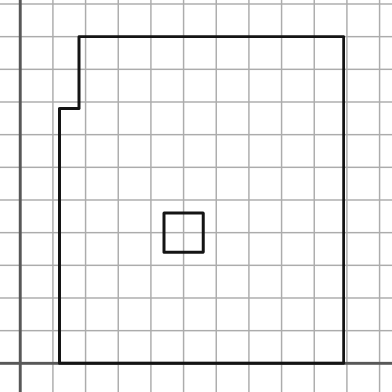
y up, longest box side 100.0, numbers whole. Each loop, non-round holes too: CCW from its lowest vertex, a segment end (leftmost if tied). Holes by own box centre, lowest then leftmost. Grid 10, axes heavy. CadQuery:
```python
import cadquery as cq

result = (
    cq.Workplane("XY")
    .moveTo(12.0, 0.0)
    .lineTo(99.0, 0.0)
    .lineTo(99.0, 100.0)
    .lineTo(18.0, 100.0)
    .lineTo(18.0, 78.0)
    .lineTo(12.0, 78.0)
    .close()
    .moveTo(44.0, 34.0)
    .lineTo(56.0, 34.0)
    .lineTo(56.0, 46.0)
    .lineTo(44.0, 46.0)
    .close()
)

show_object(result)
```